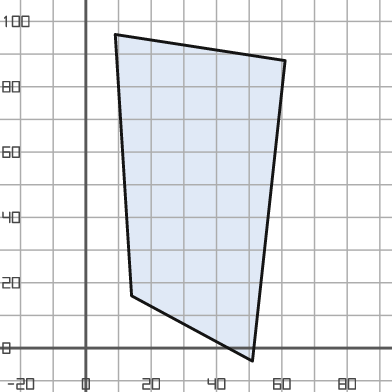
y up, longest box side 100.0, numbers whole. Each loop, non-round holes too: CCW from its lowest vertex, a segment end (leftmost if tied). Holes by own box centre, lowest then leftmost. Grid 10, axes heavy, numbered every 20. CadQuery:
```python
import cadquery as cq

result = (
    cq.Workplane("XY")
    .moveTo(51.0, -4.0)
    .lineTo(61.0, 88.0)
    .lineTo(9.0, 96.0)
    .lineTo(14.0, 16.0)
    .close()
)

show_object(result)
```